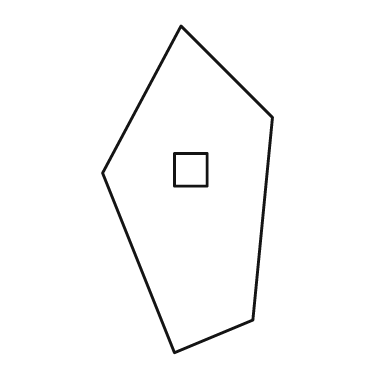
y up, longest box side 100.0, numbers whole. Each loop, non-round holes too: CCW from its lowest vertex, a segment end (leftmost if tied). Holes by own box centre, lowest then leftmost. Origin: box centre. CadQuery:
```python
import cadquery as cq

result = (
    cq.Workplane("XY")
    .moveTo(-4.0, -50.0)
    .lineTo(20.0, -40.0)
    .lineTo(26.0, 22.0)
    .lineTo(-2.0, 50.0)
    .lineTo(-26.0, 5.0)
    .close()
    .moveTo(-4.0, 1.0)
    .lineTo(6.0, 1.0)
    .lineTo(6.0, 11.0)
    .lineTo(-4.0, 11.0)
    .close()
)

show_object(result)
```